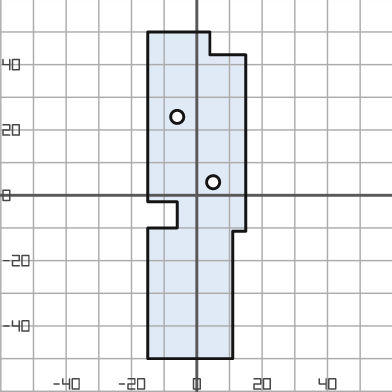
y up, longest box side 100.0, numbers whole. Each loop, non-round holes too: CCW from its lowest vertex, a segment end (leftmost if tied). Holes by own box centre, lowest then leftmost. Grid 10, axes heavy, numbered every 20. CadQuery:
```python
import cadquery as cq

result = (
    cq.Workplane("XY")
    .moveTo(-15.0, -50.0)
    .lineTo(11.0, -50.0)
    .lineTo(11.0, -11.0)
    .lineTo(15.0, -11.0)
    .lineTo(15.0, 43.0)
    .lineTo(4.0, 43.0)
    .lineTo(4.0, 50.0)
    .lineTo(-15.0, 50.0)
    .lineTo(-15.0, -2.0)
    .lineTo(-6.0, -2.0)
    .lineTo(-6.0, -10.0)
    .lineTo(-15.0, -10.0)
    .close()
    .moveTo(5.0, 4.0)
    .circle(2.0)
    .moveTo(-6.0, 24.0)
    .circle(2.0)
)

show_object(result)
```